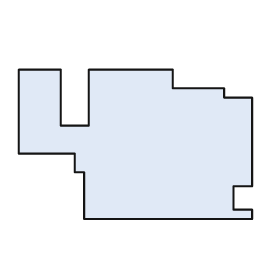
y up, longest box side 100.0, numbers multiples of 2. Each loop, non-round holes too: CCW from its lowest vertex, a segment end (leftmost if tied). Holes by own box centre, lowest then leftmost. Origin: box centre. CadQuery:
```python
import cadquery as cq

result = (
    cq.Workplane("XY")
    .moveTo(-22.0, -32.0)
    .lineTo(50.0, -32.0)
    .lineTo(50.0, -28.0)
    .lineTo(42.0, -28.0)
    .lineTo(42.0, -18.0)
    .lineTo(50.0, -18.0)
    .lineTo(50.0, 20.0)
    .lineTo(38.0, 20.0)
    .lineTo(38.0, 24.0)
    .lineTo(16.0, 24.0)
    .lineTo(16.0, 32.0)
    .lineTo(-20.0, 32.0)
    .lineTo(-20.0, 8.0)
    .lineTo(-32.0, 8.0)
    .lineTo(-32.0, 32.0)
    .lineTo(-50.0, 32.0)
    .lineTo(-50.0, -4.0)
    .lineTo(-26.0, -4.0)
    .lineTo(-26.0, -12.0)
    .lineTo(-22.0, -12.0)
    .close()
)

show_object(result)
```